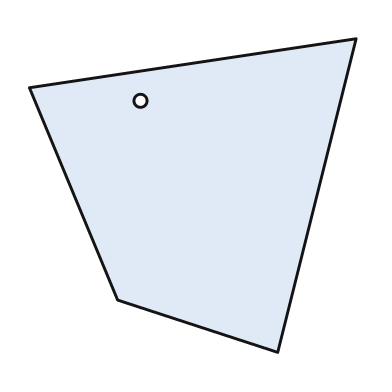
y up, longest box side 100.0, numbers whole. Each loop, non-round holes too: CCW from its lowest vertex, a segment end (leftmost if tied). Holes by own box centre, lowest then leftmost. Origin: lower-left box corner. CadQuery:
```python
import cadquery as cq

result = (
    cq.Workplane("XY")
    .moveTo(76.0, 0.0)
    .lineTo(100.0, 96.0)
    .lineTo(0.0, 81.0)
    .lineTo(27.0, 16.0)
    .close()
    .moveTo(34.0, 77.0)
    .circle(2.0)
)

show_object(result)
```